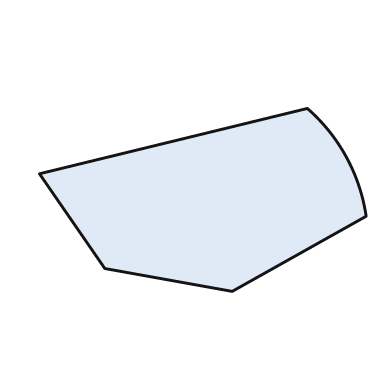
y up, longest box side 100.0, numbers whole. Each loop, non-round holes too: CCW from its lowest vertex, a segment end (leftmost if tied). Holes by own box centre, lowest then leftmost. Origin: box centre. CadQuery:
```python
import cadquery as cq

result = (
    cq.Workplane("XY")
    .moveTo(9.0, -28.0)
    .lineTo(50.0, -5.0)
    .threePointArc((44.0, 13.0), (32.0, 28.0))
    .lineTo(-50.0, 8.0)
    .lineTo(-30.0, -21.0)
    .close()
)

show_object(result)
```